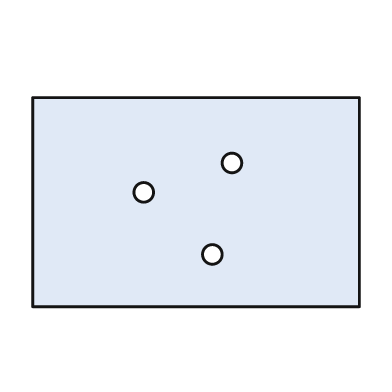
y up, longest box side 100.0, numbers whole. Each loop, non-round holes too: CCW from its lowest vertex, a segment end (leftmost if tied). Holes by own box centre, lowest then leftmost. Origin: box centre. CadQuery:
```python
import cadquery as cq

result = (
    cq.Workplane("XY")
    .moveTo(-50.0, -32.0)
    .lineTo(50.0, -32.0)
    .lineTo(50.0, 32.0)
    .lineTo(-50.0, 32.0)
    .close()
    .moveTo(5.0, -16.0)
    .circle(3.0)
    .moveTo(-16.0, 3.0)
    .circle(3.0)
    .moveTo(11.0, 12.0)
    .circle(3.0)
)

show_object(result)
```